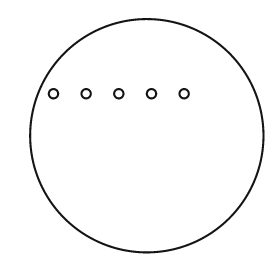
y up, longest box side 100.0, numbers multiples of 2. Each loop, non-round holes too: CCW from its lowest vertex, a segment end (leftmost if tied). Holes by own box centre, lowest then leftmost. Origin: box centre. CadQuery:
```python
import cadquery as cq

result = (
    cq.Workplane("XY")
    .moveTo(0.0, 0.0)
    .circle(50.0)
    .moveTo(-40.0, 18.0)
    .circle(2.0)
    .moveTo(-26.0, 18.0)
    .circle(2.0)
    .moveTo(-12.0, 18.0)
    .circle(2.0)
    .moveTo(2.0, 18.0)
    .circle(2.0)
    .moveTo(16.0, 18.0)
    .circle(2.0)
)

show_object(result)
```